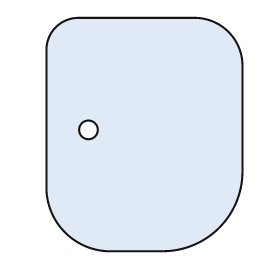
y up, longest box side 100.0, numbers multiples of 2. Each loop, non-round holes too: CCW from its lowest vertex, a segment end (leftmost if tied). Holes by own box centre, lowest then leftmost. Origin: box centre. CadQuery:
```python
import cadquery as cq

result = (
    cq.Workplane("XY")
    .moveTo(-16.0, -50.0)
    .lineTo(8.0, -50.0)
    .threePointArc((32.0, -40.0), (42.0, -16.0))
    .lineTo(42.0, 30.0)
    .threePointArc((36.0, 44.0), (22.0, 50.0))
    .lineTo(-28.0, 50.0)
    .threePointArc((-38.0, 46.0), (-42.0, 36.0))
    .lineTo(-42.0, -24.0)
    .threePointArc((-34.0, -42.0), (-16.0, -50.0))
    .close()
    .moveTo(-24.0, 2.0)
    .circle(4.0)
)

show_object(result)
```